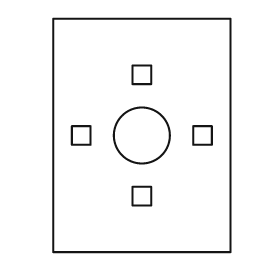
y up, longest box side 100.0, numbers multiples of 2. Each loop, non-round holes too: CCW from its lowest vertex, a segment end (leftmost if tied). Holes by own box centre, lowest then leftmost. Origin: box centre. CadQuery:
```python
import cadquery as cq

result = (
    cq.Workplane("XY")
    .moveTo(-38.0, -50.0)
    .lineTo(38.0, -50.0)
    .lineTo(38.0, 50.0)
    .lineTo(-38.0, 50.0)
    .close()
    .moveTo(-4.0, -30.0)
    .lineTo(4.0, -30.0)
    .lineTo(4.0, -22.0)
    .lineTo(-4.0, -22.0)
    .close()
    .moveTo(-30.0, -4.0)
    .lineTo(-22.0, -4.0)
    .lineTo(-22.0, 4.0)
    .lineTo(-30.0, 4.0)
    .close()
    .moveTo(0.0, 0.0)
    .circle(12.0)
    .moveTo(22.0, -4.0)
    .lineTo(30.0, -4.0)
    .lineTo(30.0, 4.0)
    .lineTo(22.0, 4.0)
    .close()
    .moveTo(-4.0, 22.0)
    .lineTo(4.0, 22.0)
    .lineTo(4.0, 30.0)
    .lineTo(-4.0, 30.0)
    .close()
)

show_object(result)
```